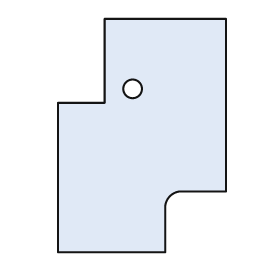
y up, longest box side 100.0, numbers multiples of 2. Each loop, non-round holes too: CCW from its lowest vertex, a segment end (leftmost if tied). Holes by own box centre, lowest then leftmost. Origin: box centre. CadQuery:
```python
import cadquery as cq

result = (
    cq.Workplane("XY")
    .moveTo(-36.0, -50.0)
    .lineTo(10.0, -50.0)
    .lineTo(10.0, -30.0)
    .threePointArc((12.0, -26.0), (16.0, -24.0))
    .lineTo(36.0, -24.0)
    .lineTo(36.0, 50.0)
    .lineTo(-16.0, 50.0)
    .lineTo(-16.0, 14.0)
    .lineTo(-36.0, 14.0)
    .close()
    .moveTo(-4.0, 20.0)
    .circle(4.0)
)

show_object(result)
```